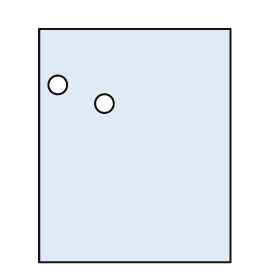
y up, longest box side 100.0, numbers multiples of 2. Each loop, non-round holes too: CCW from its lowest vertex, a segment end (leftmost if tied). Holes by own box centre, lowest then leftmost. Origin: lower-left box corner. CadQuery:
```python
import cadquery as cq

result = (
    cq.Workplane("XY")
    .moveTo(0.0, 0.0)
    .lineTo(82.0, 0.0)
    .lineTo(82.0, 100.0)
    .lineTo(0.0, 100.0)
    .close()
    .moveTo(28.0, 68.0)
    .circle(4.0)
    .moveTo(8.0, 76.0)
    .circle(4.0)
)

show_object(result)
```